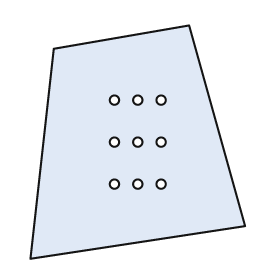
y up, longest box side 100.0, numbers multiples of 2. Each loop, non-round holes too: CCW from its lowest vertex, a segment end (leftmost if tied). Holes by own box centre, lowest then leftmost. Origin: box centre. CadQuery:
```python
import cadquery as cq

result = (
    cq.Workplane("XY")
    .moveTo(-46.0, -50.0)
    .lineTo(46.0, -36.0)
    .lineTo(22.0, 50.0)
    .lineTo(-36.0, 40.0)
    .close()
    .moveTo(-10.0, -18.0)
    .circle(2.0)
    .moveTo(0.0, -18.0)
    .circle(2.0)
    .moveTo(10.0, -18.0)
    .circle(2.0)
    .moveTo(-10.0, 0.0)
    .circle(2.0)
    .moveTo(0.0, 0.0)
    .circle(2.0)
    .moveTo(10.0, 0.0)
    .circle(2.0)
    .moveTo(-10.0, 18.0)
    .circle(2.0)
    .moveTo(0.0, 18.0)
    .circle(2.0)
    .moveTo(10.0, 18.0)
    .circle(2.0)
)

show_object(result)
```